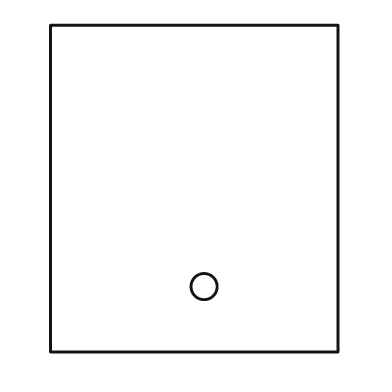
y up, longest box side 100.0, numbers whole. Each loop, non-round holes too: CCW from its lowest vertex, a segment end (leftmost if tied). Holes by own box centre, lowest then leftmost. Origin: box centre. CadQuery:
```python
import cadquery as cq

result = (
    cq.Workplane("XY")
    .moveTo(-44.0, -50.0)
    .lineTo(44.0, -50.0)
    .lineTo(44.0, 50.0)
    .lineTo(-44.0, 50.0)
    .close()
    .moveTo(3.0, -30.0)
    .circle(4.0)
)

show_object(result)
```